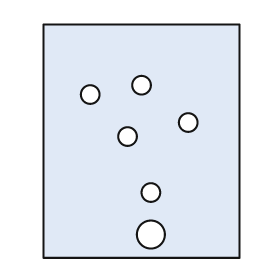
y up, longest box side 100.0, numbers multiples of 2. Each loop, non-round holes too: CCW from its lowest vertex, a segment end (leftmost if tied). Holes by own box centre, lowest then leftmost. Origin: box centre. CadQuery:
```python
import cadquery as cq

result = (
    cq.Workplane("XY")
    .moveTo(-42.0, -50.0)
    .lineTo(42.0, -50.0)
    .lineTo(42.0, 50.0)
    .lineTo(-42.0, 50.0)
    .close()
    .moveTo(4.0, -40.0)
    .circle(6.0)
    .moveTo(4.0, -22.0)
    .circle(4.0)
    .moveTo(-6.0, 2.0)
    .circle(4.0)
    .moveTo(20.0, 8.0)
    .circle(4.0)
    .moveTo(-22.0, 20.0)
    .circle(4.0)
    .moveTo(0.0, 24.0)
    .circle(4.0)
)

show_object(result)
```